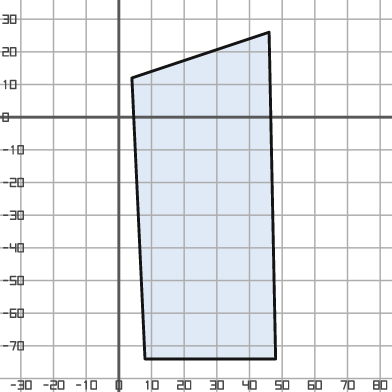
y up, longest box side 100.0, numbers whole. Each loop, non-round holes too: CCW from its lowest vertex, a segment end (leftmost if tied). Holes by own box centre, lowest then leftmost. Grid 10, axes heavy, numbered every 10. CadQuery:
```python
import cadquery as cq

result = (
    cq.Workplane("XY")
    .moveTo(8.0, -74.0)
    .lineTo(48.0, -74.0)
    .lineTo(46.0, 26.0)
    .lineTo(4.0, 12.0)
    .close()
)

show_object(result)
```